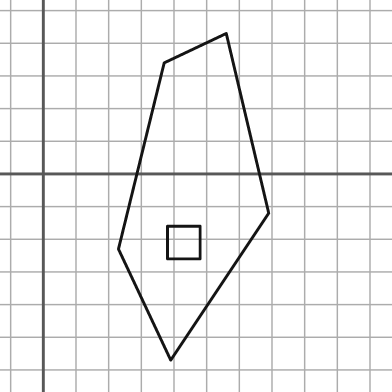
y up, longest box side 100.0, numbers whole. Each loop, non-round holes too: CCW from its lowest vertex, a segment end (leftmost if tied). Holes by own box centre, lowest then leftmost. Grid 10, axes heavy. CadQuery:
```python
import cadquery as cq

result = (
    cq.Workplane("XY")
    .moveTo(39.0, -57.0)
    .lineTo(69.0, -12.0)
    .lineTo(56.0, 43.0)
    .lineTo(37.0, 34.0)
    .lineTo(23.0, -23.0)
    .close()
    .moveTo(38.0, -26.0)
    .lineTo(48.0, -26.0)
    .lineTo(48.0, -16.0)
    .lineTo(38.0, -16.0)
    .close()
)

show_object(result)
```